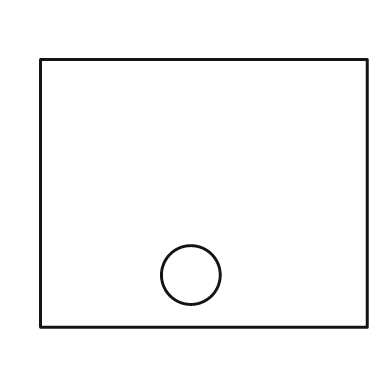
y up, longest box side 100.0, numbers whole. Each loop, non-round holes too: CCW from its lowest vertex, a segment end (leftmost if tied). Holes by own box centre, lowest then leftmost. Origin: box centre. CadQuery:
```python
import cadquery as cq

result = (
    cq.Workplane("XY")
    .moveTo(-50.0, -41.0)
    .lineTo(50.0, -41.0)
    .lineTo(50.0, 41.0)
    .lineTo(-50.0, 41.0)
    .close()
    .moveTo(-4.0, -25.0)
    .circle(9.0)
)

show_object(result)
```